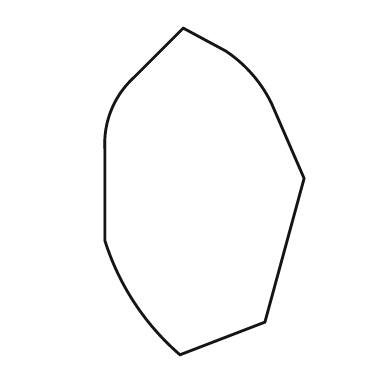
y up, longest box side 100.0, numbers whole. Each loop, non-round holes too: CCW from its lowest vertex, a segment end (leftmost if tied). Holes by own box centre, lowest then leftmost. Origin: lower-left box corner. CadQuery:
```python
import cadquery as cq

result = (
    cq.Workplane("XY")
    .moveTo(23.0, 0.0)
    .lineTo(49.0, 10.0)
    .lineTo(61.0, 54.0)
    .lineTo(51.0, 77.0)
    .threePointArc((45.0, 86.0), (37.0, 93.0))
    .lineTo(24.0, 100.0)
    .lineTo(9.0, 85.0)
    .threePointArc((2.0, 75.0), (0.0, 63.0))
    .lineTo(0.0, 35.0)
    .threePointArc((9.0, 16.0), (23.0, 0.0))
    .close()
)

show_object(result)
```